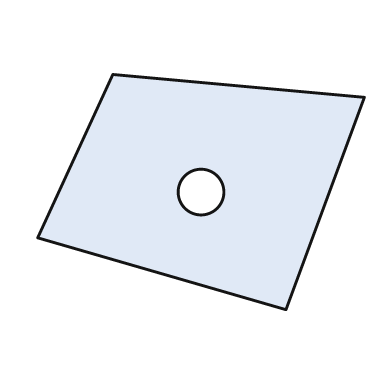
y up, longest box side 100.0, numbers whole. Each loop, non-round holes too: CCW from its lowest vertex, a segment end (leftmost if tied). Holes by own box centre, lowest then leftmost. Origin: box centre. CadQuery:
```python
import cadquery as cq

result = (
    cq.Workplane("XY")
    .moveTo(26.0, -36.0)
    .lineTo(50.0, 29.0)
    .lineTo(-27.0, 36.0)
    .lineTo(-50.0, -14.0)
    .close()
    .moveTo(0.0, 0.0)
    .circle(7.0)
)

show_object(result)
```